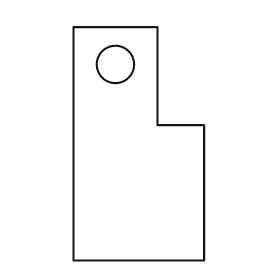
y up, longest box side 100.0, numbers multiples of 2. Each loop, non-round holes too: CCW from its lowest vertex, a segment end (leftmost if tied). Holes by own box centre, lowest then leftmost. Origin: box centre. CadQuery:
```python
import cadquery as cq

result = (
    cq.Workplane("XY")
    .moveTo(-28.0, -50.0)
    .lineTo(28.0, -50.0)
    .lineTo(28.0, 8.0)
    .lineTo(8.0, 8.0)
    .lineTo(8.0, 50.0)
    .lineTo(-28.0, 50.0)
    .close()
    .moveTo(-10.0, 34.0)
    .circle(8.0)
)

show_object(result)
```